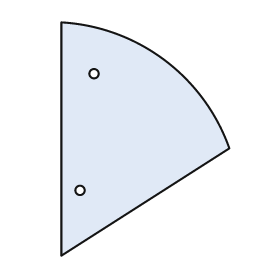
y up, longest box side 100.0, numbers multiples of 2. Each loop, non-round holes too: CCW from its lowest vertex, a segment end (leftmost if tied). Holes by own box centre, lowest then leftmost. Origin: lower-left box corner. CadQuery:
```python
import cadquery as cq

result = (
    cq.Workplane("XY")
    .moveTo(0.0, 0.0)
    .lineTo(72.0, 46.0)
    .threePointArc((44.0, 84.0), (0.0, 100.0))
    .close()
    .moveTo(8.0, 28.0)
    .circle(2.0)
    .moveTo(14.0, 78.0)
    .circle(2.0)
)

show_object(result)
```